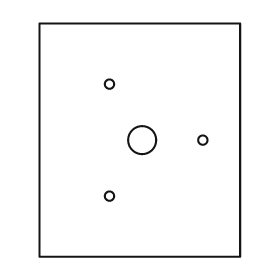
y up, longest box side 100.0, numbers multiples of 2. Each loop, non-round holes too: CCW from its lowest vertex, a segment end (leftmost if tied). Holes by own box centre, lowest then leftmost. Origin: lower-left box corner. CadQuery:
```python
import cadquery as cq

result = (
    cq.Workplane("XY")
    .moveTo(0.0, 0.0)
    .lineTo(86.0, 0.0)
    .lineTo(86.0, 100.0)
    .lineTo(0.0, 100.0)
    .close()
    .moveTo(30.0, 26.0)
    .circle(2.0)
    .moveTo(44.0, 50.0)
    .circle(6.0)
    .moveTo(70.0, 50.0)
    .circle(2.0)
    .moveTo(30.0, 74.0)
    .circle(2.0)
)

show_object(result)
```